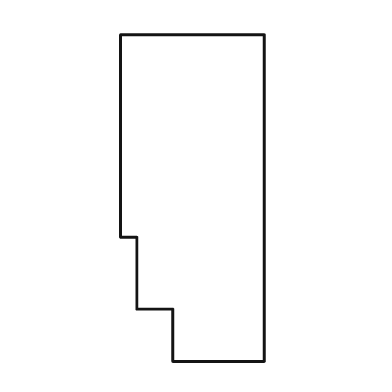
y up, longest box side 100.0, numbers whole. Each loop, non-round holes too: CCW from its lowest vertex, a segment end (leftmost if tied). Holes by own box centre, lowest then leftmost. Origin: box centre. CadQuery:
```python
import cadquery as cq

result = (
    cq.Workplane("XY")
    .moveTo(-6.0, -50.0)
    .lineTo(22.0, -50.0)
    .lineTo(22.0, 50.0)
    .lineTo(-22.0, 50.0)
    .lineTo(-22.0, -12.0)
    .lineTo(-17.0, -12.0)
    .lineTo(-17.0, -34.0)
    .lineTo(-6.0, -34.0)
    .close()
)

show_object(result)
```